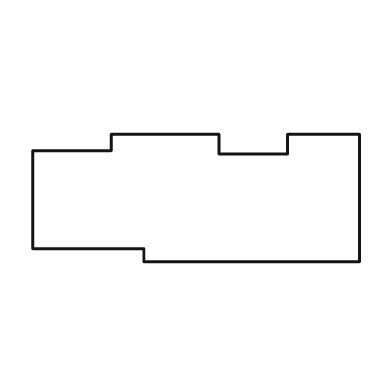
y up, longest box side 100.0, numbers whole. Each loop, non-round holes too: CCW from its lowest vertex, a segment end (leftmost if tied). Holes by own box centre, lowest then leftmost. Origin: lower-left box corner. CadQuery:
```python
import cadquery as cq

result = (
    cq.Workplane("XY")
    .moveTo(34.0, 0.0)
    .lineTo(100.0, 0.0)
    .lineTo(100.0, 39.0)
    .lineTo(78.0, 39.0)
    .lineTo(78.0, 33.0)
    .lineTo(57.0, 33.0)
    .lineTo(57.0, 39.0)
    .lineTo(24.0, 39.0)
    .lineTo(24.0, 34.0)
    .lineTo(0.0, 34.0)
    .lineTo(0.0, 4.0)
    .lineTo(34.0, 4.0)
    .close()
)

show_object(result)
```